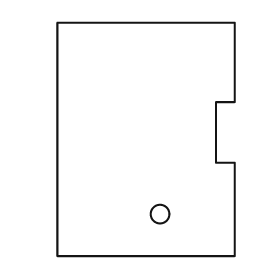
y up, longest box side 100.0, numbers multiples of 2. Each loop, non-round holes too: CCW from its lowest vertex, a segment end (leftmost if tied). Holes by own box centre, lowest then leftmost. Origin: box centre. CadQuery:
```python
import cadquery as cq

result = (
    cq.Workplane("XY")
    .moveTo(-38.0, -50.0)
    .lineTo(38.0, -50.0)
    .lineTo(38.0, -10.0)
    .lineTo(30.0, -10.0)
    .lineTo(30.0, 16.0)
    .lineTo(38.0, 16.0)
    .lineTo(38.0, 50.0)
    .lineTo(-38.0, 50.0)
    .close()
    .moveTo(6.0, -32.0)
    .circle(4.0)
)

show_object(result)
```